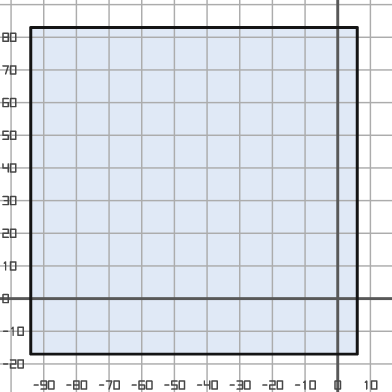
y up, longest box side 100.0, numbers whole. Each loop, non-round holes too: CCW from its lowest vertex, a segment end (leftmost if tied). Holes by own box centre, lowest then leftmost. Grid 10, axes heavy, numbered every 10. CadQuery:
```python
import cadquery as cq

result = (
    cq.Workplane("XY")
    .moveTo(-94.0, -17.0)
    .lineTo(6.0, -17.0)
    .lineTo(6.0, 83.0)
    .lineTo(-94.0, 83.0)
    .close()
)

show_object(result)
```